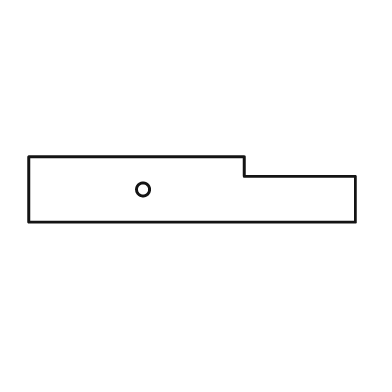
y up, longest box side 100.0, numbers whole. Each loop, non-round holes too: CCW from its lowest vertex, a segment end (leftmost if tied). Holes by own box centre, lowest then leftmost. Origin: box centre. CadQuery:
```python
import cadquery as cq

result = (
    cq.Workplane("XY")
    .moveTo(-50.0, -10.0)
    .lineTo(50.0, -10.0)
    .lineTo(50.0, 4.0)
    .lineTo(16.0, 4.0)
    .lineTo(16.0, 10.0)
    .lineTo(-50.0, 10.0)
    .close()
    .moveTo(-15.0, 0.0)
    .circle(2.0)
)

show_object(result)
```